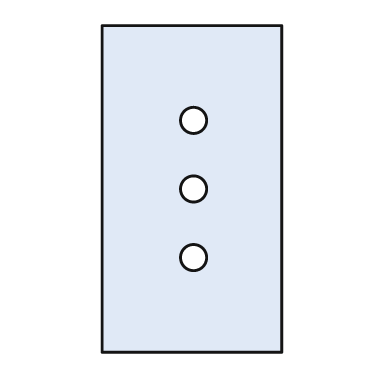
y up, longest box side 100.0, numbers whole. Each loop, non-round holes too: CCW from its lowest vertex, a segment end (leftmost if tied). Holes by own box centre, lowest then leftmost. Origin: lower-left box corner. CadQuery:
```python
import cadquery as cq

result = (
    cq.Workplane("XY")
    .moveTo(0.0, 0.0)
    .lineTo(55.0, 0.0)
    .lineTo(55.0, 100.0)
    .lineTo(0.0, 100.0)
    .close()
    .moveTo(28.0, 29.0)
    .circle(4.0)
    .moveTo(28.0, 50.0)
    .circle(4.0)
    .moveTo(28.0, 71.0)
    .circle(4.0)
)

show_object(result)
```